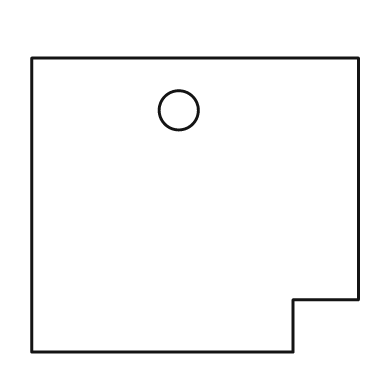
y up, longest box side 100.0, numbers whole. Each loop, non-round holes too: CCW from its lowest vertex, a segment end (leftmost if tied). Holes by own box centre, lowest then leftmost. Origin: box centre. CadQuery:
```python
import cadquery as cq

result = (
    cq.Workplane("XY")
    .moveTo(-50.0, -45.0)
    .lineTo(30.0, -45.0)
    .lineTo(30.0, -29.0)
    .lineTo(50.0, -29.0)
    .lineTo(50.0, 45.0)
    .lineTo(-50.0, 45.0)
    .close()
    .moveTo(-5.0, 29.0)
    .circle(6.0)
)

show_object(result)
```